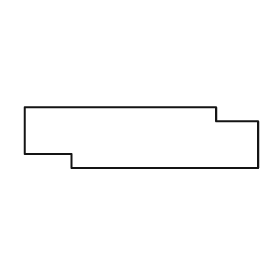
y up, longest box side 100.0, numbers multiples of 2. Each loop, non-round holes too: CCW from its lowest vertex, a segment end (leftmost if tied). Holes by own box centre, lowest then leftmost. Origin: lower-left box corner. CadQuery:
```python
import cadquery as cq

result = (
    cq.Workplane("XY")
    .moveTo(20.0, 0.0)
    .lineTo(100.0, 0.0)
    .lineTo(100.0, 20.0)
    .lineTo(82.0, 20.0)
    .lineTo(82.0, 26.0)
    .lineTo(0.0, 26.0)
    .lineTo(0.0, 6.0)
    .lineTo(20.0, 6.0)
    .close()
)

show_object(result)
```